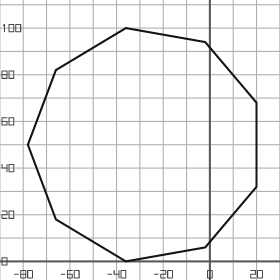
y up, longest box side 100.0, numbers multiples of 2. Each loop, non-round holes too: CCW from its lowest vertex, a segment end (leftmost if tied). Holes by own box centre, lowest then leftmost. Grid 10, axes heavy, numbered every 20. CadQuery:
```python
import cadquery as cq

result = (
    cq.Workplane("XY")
    .moveTo(-36.0, 0.0)
    .lineTo(-2.0, 6.0)
    .lineTo(20.0, 32.0)
    .lineTo(20.0, 68.0)
    .lineTo(-2.0, 94.0)
    .lineTo(-36.0, 100.0)
    .lineTo(-66.0, 82.0)
    .lineTo(-78.0, 50.0)
    .lineTo(-66.0, 18.0)
    .close()
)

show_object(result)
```